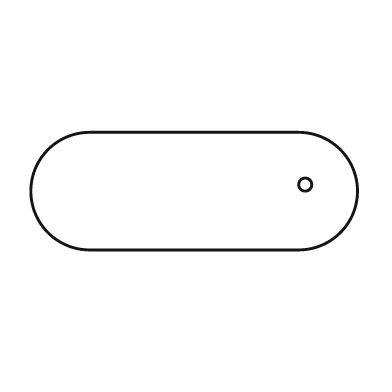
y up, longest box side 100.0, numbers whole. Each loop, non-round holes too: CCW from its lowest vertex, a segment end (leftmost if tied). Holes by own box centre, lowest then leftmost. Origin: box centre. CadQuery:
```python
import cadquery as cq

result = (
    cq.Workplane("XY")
    .moveTo(-32.0, -18.0)
    .lineTo(32.0, -18.0)
    .threePointArc((50.0, 0.0), (32.0, 18.0))
    .lineTo(-32.0, 18.0)
    .threePointArc((-50.0, 0.0), (-32.0, -18.0))
    .close()
    .moveTo(34.0, 2.0)
    .circle(2.0)
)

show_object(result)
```